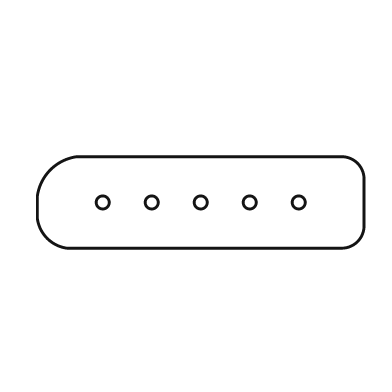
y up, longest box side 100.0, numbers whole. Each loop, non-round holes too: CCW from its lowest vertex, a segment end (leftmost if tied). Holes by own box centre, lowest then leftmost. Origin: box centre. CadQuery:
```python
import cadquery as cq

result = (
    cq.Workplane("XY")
    .moveTo(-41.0, -14.0)
    .lineTo(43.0, -14.0)
    .threePointArc((48.0, -12.0), (50.0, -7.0))
    .lineTo(50.0, 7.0)
    .threePointArc((48.0, 12.0), (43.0, 14.0))
    .lineTo(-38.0, 14.0)
    .threePointArc((-46.0, 10.0), (-50.0, 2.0))
    .lineTo(-50.0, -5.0)
    .threePointArc((-47.0, -11.0), (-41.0, -14.0))
    .close()
    .moveTo(-30.0, 0.0)
    .circle(2.0)
    .moveTo(-15.0, 0.0)
    .circle(2.0)
    .moveTo(0.0, 0.0)
    .circle(2.0)
    .moveTo(15.0, 0.0)
    .circle(2.0)
    .moveTo(30.0, 0.0)
    .circle(2.0)
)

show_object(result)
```